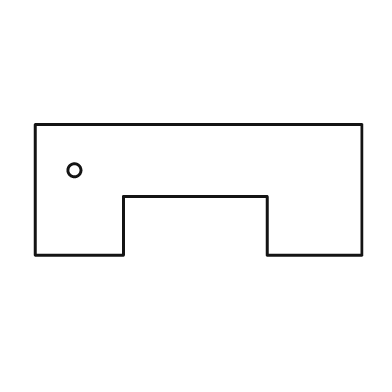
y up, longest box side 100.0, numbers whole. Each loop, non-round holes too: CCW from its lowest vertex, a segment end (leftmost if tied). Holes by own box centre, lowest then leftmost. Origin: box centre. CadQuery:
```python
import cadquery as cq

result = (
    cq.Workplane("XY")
    .moveTo(-50.0, -20.0)
    .lineTo(-23.0, -20.0)
    .lineTo(-23.0, -2.0)
    .lineTo(21.0, -2.0)
    .lineTo(21.0, -20.0)
    .lineTo(50.0, -20.0)
    .lineTo(50.0, 20.0)
    .lineTo(-50.0, 20.0)
    .close()
    .moveTo(-38.0, 6.0)
    .circle(2.0)
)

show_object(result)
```